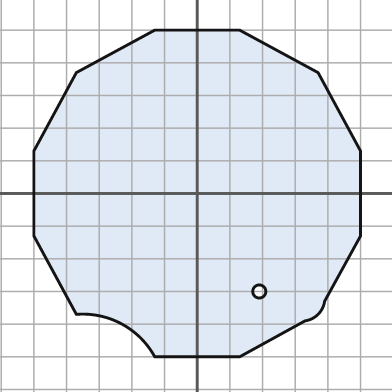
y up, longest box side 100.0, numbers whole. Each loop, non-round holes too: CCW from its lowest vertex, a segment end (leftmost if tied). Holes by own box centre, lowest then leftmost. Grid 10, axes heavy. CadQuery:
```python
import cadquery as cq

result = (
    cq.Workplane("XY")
    .moveTo(-13.0, -50.0)
    .lineTo(13.0, -50.0)
    .lineTo(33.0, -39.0)
    .threePointArc((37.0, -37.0), (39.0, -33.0))
    .lineTo(50.0, -13.0)
    .lineTo(50.0, 13.0)
    .lineTo(37.0, 37.0)
    .lineTo(13.0, 50.0)
    .lineTo(-13.0, 50.0)
    .lineTo(-37.0, 37.0)
    .lineTo(-50.0, 13.0)
    .lineTo(-50.0, -13.0)
    .lineTo(-37.0, -37.0)
    .threePointArc((-23.0, -40.0), (-13.0, -50.0))
    .close()
    .moveTo(19.0, -30.0)
    .circle(2.0)
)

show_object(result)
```